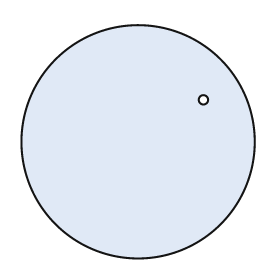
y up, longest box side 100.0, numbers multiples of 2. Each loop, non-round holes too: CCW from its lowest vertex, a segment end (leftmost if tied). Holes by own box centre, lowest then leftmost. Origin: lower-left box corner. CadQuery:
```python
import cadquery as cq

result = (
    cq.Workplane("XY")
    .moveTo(50.0, 50.0)
    .circle(50.0)
    .moveTo(78.0, 68.0)
    .circle(2.0)
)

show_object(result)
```